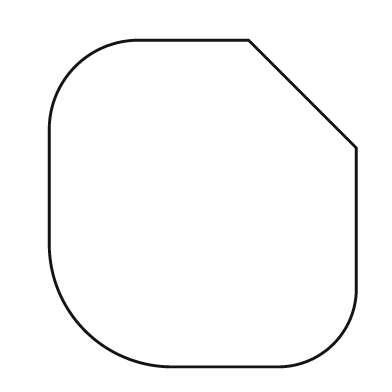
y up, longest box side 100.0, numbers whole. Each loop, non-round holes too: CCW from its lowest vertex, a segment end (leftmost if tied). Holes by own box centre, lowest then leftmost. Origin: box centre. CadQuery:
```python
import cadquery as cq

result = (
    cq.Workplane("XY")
    .moveTo(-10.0, -50.0)
    .lineTo(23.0, -50.0)
    .threePointArc((40.0, -43.0), (47.0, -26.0))
    .lineTo(47.0, 17.0)
    .lineTo(14.0, 50.0)
    .lineTo(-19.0, 50.0)
    .threePointArc((-39.0, 42.0), (-47.0, 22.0))
    .lineTo(-47.0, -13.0)
    .threePointArc((-36.0, -39.0), (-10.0, -50.0))
    .close()
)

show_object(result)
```